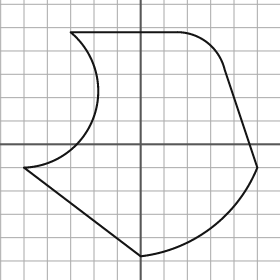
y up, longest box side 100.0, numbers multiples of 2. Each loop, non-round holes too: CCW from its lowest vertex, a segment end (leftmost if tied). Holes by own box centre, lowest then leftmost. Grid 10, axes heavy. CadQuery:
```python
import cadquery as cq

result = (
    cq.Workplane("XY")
    .moveTo(0.0, -48.0)
    .threePointArc((30.0, -36.0), (50.0, -10.0))
    .lineTo(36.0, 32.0)
    .threePointArc((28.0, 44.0), (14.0, 48.0))
    .lineTo(-30.0, 48.0)
    .threePointArc((-20.0, 12.0), (-50.0, -10.0))
    .close()
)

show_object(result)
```